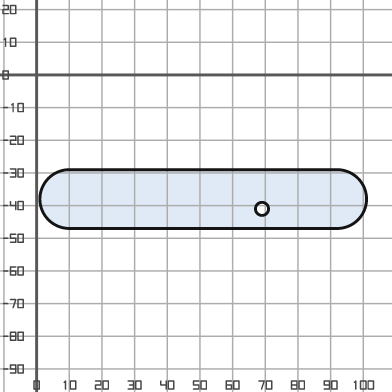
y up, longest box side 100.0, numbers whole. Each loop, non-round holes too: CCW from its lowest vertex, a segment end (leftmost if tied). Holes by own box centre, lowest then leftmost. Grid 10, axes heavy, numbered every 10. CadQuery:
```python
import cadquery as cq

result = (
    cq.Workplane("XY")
    .moveTo(10.0, -47.0)
    .lineTo(92.0, -47.0)
    .threePointArc((101.0, -38.0), (92.0, -29.0))
    .lineTo(10.0, -29.0)
    .threePointArc((1.0, -38.0), (10.0, -47.0))
    .close()
    .moveTo(69.0, -41.0)
    .circle(2.0)
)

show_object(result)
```